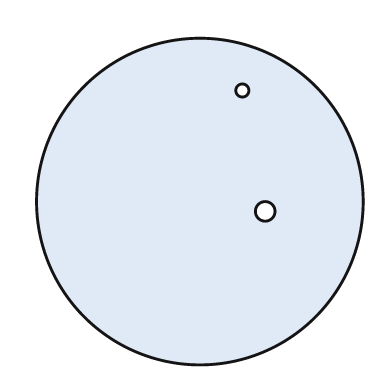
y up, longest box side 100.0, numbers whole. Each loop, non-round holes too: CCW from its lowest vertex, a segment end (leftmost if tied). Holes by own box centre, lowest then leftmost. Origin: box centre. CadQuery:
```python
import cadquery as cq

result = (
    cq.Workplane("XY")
    .moveTo(0.0, 0.0)
    .circle(50.0)
    .moveTo(20.0, -3.0)
    .circle(3.0)
    .moveTo(13.0, 34.0)
    .circle(2.0)
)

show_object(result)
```